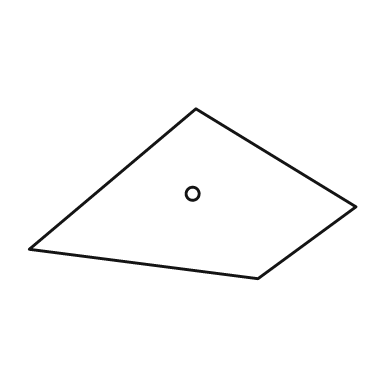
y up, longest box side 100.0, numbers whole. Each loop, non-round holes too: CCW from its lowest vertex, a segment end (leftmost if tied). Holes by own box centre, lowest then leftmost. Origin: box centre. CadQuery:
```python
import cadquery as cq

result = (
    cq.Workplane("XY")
    .moveTo(20.0, -26.0)
    .lineTo(50.0, -4.0)
    .lineTo(1.0, 26.0)
    .lineTo(-50.0, -17.0)
    .close()
    .moveTo(0.0, 0.0)
    .circle(2.0)
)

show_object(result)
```